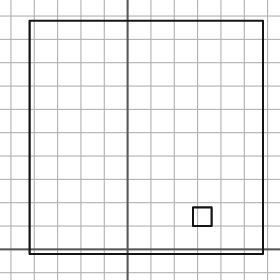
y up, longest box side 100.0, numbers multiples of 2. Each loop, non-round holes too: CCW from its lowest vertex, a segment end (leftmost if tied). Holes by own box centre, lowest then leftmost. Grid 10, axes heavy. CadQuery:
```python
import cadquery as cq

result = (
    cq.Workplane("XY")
    .moveTo(-42.0, -2.0)
    .lineTo(58.0, -2.0)
    .lineTo(58.0, 98.0)
    .lineTo(-42.0, 98.0)
    .close()
    .moveTo(28.0, 10.0)
    .lineTo(36.0, 10.0)
    .lineTo(36.0, 18.0)
    .lineTo(28.0, 18.0)
    .close()
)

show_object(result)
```